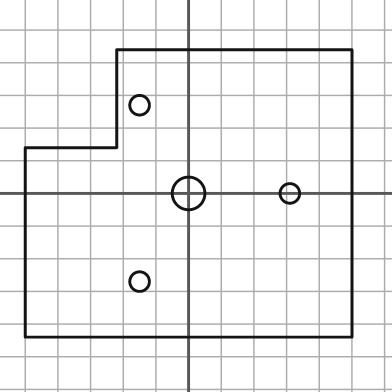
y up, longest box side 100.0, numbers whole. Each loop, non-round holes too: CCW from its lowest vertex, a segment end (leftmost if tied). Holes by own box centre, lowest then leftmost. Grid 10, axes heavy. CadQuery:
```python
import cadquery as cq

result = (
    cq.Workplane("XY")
    .moveTo(-50.0, -44.0)
    .lineTo(50.0, -44.0)
    .lineTo(50.0, 44.0)
    .lineTo(-22.0, 44.0)
    .lineTo(-22.0, 14.0)
    .lineTo(-50.0, 14.0)
    .close()
    .moveTo(-15.0, -27.0)
    .circle(3.0)
    .moveTo(0.0, 0.0)
    .circle(5.0)
    .moveTo(31.0, 0.0)
    .circle(3.0)
    .moveTo(-15.0, 27.0)
    .circle(3.0)
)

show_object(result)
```